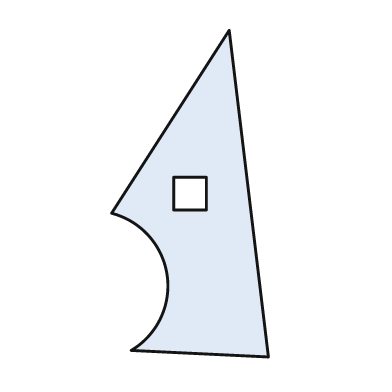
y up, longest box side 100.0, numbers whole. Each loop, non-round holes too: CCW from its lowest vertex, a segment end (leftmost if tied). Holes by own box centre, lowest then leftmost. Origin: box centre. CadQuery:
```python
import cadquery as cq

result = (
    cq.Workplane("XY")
    .moveTo(24.0, -50.0)
    .lineTo(12.0, 50.0)
    .lineTo(-24.0, -6.0)
    .threePointArc((-7.0, -25.0), (-18.0, -48.0))
    .close()
    .moveTo(-5.0, -5.0)
    .lineTo(5.0, -5.0)
    .lineTo(5.0, 5.0)
    .lineTo(-5.0, 5.0)
    .close()
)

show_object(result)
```